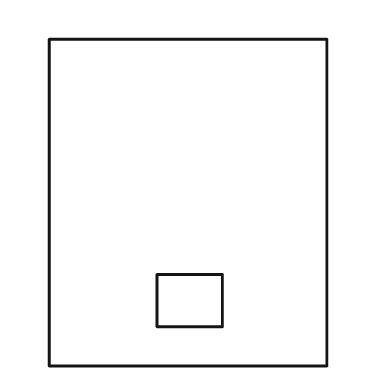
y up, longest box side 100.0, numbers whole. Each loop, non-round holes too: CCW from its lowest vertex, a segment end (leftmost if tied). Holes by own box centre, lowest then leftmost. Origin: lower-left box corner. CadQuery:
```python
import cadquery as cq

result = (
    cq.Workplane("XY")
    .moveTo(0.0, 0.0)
    .lineTo(85.0, 0.0)
    .lineTo(85.0, 100.0)
    .lineTo(0.0, 100.0)
    .close()
    .moveTo(33.0, 12.0)
    .lineTo(53.0, 12.0)
    .lineTo(53.0, 28.0)
    .lineTo(33.0, 28.0)
    .close()
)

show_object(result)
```